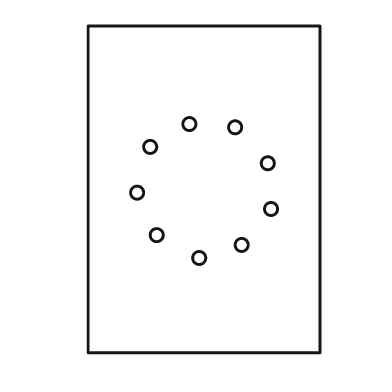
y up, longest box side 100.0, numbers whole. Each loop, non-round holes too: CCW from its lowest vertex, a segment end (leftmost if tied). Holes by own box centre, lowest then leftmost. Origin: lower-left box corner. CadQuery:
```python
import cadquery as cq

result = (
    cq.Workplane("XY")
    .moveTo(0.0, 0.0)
    .lineTo(71.0, 0.0)
    .lineTo(71.0, 100.0)
    .lineTo(0.0, 100.0)
    .close()
    .moveTo(34.0, 29.0)
    .circle(2.0)
    .moveTo(47.0, 33.0)
    .circle(2.0)
    .moveTo(21.0, 36.0)
    .circle(2.0)
    .moveTo(56.0, 44.0)
    .circle(2.0)
    .moveTo(15.0, 49.0)
    .circle(2.0)
    .moveTo(55.0, 58.0)
    .circle(2.0)
    .moveTo(19.0, 63.0)
    .circle(2.0)
    .moveTo(45.0, 69.0)
    .circle(2.0)
    .moveTo(31.0, 70.0)
    .circle(2.0)
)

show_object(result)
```